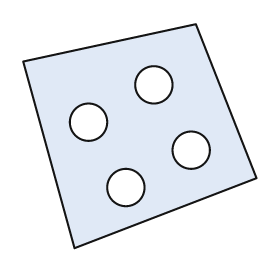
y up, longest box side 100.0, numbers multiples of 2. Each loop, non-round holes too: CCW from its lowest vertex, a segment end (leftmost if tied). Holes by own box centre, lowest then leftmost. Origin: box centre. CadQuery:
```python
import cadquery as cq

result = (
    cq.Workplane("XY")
    .moveTo(-28.0, -48.0)
    .lineTo(50.0, -18.0)
    .lineTo(24.0, 48.0)
    .lineTo(-50.0, 32.0)
    .close()
    .moveTo(-6.0, -22.0)
    .circle(8.0)
    .moveTo(22.0, -6.0)
    .circle(8.0)
    .moveTo(-22.0, 6.0)
    .circle(8.0)
    .moveTo(6.0, 22.0)
    .circle(8.0)
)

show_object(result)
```